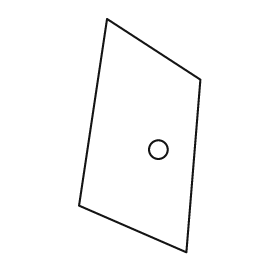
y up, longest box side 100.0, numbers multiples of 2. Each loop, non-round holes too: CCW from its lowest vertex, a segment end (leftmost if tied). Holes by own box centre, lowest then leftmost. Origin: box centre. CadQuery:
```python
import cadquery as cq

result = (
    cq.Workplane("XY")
    .moveTo(20.0, -50.0)
    .lineTo(26.0, 24.0)
    .lineTo(-14.0, 50.0)
    .lineTo(-26.0, -30.0)
    .close()
    .moveTo(8.0, -6.0)
    .circle(4.0)
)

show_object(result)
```